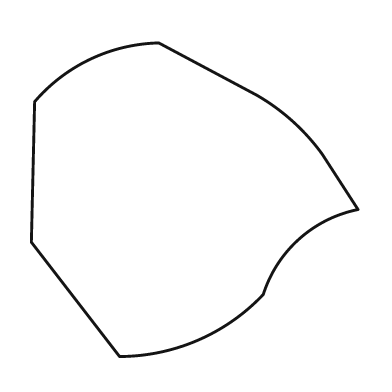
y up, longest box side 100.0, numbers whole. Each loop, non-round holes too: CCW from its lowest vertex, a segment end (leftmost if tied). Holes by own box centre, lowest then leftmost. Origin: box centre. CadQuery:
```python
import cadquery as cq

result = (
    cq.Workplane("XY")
    .moveTo(-23.0, -48.0)
    .threePointArc((1.0, -43.0), (21.0, -29.0))
    .threePointArc((32.0, -12.0), (50.0, -3.0))
    .lineTo(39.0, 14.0)
    .threePointArc((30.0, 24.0), (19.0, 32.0))
    .lineTo(-11.0, 48.0)
    .threePointArc((-32.0, 43.0), (-49.0, 30.0))
    .lineTo(-50.0, -13.0)
    .close()
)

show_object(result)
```